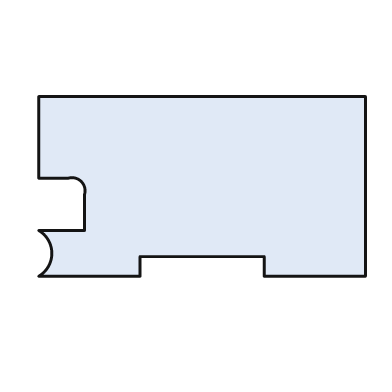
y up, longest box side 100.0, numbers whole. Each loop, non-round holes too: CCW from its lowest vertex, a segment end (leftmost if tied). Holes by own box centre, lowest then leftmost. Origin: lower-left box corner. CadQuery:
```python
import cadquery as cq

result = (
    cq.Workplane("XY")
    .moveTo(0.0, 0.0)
    .lineTo(31.0, 0.0)
    .lineTo(31.0, 6.0)
    .lineTo(69.0, 6.0)
    .lineTo(69.0, 0.0)
    .lineTo(100.0, 0.0)
    .lineTo(100.0, 55.0)
    .lineTo(0.0, 55.0)
    .lineTo(0.0, 30.0)
    .lineTo(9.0, 30.0)
    .threePointArc((13.0, 29.0), (14.0, 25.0))
    .lineTo(14.0, 14.0)
    .lineTo(0.0, 14.0)
    .threePointArc((4.0, 7.0), (0.0, 0.0))
    .close()
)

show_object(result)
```